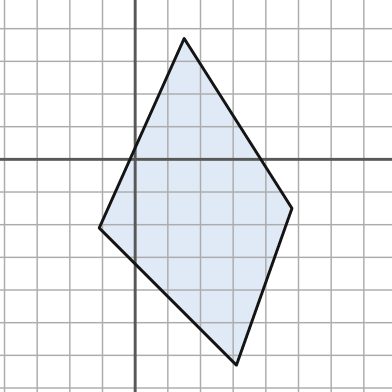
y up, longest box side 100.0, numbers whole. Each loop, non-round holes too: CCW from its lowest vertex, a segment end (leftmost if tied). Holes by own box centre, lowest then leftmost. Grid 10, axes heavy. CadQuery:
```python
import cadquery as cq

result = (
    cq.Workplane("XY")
    .moveTo(31.0, -63.0)
    .lineTo(48.0, -15.0)
    .lineTo(15.0, 37.0)
    .lineTo(-11.0, -21.0)
    .close()
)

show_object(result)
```